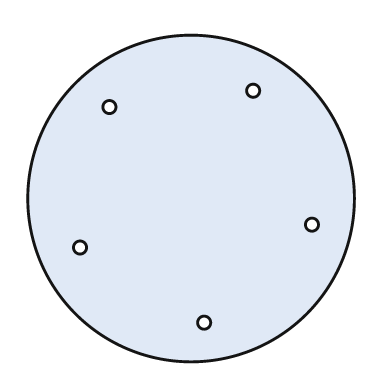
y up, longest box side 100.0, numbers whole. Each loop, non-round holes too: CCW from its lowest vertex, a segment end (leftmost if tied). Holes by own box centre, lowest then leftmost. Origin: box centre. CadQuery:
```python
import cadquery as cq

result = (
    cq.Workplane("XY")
    .moveTo(0.0, 0.0)
    .circle(50.0)
    .moveTo(4.0, -38.0)
    .circle(2.0)
    .moveTo(-34.0, -15.0)
    .circle(2.0)
    .moveTo(37.0, -8.0)
    .circle(2.0)
    .moveTo(-25.0, 28.0)
    .circle(2.0)
    .moveTo(19.0, 33.0)
    .circle(2.0)
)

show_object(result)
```